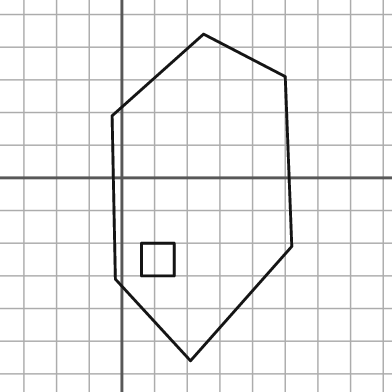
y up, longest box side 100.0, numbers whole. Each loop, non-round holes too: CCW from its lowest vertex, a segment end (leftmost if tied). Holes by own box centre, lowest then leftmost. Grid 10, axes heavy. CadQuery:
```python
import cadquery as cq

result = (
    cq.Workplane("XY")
    .moveTo(21.0, -56.0)
    .lineTo(52.0, -21.0)
    .lineTo(50.0, 31.0)
    .lineTo(25.0, 44.0)
    .lineTo(-3.0, 19.0)
    .lineTo(-2.0, -31.0)
    .close()
    .moveTo(6.0, -30.0)
    .lineTo(16.0, -30.0)
    .lineTo(16.0, -20.0)
    .lineTo(6.0, -20.0)
    .close()
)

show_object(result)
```